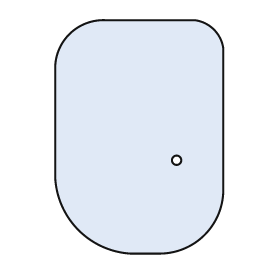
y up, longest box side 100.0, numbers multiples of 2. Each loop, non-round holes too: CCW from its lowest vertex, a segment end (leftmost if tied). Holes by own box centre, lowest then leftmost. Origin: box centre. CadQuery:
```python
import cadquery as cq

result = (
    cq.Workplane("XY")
    .moveTo(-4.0, -50.0)
    .lineTo(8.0, -50.0)
    .threePointArc((28.0, -42.0), (36.0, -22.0))
    .lineTo(36.0, 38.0)
    .threePointArc((32.0, 46.0), (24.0, 50.0))
    .lineTo(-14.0, 50.0)
    .threePointArc((-30.0, 44.0), (-36.0, 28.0))
    .lineTo(-36.0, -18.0)
    .threePointArc((-26.0, -40.0), (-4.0, -50.0))
    .close()
    .moveTo(16.0, -10.0)
    .circle(2.0)
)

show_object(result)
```